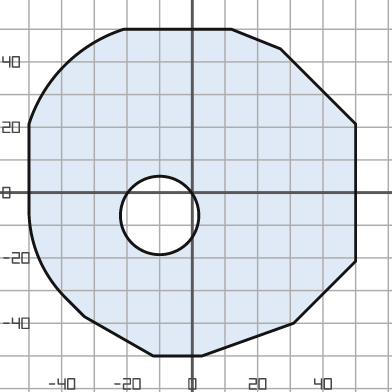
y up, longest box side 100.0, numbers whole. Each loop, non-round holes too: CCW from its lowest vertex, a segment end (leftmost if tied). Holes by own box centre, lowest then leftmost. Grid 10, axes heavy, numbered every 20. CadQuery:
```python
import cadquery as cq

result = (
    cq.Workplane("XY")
    .moveTo(-12.0, -50.0)
    .lineTo(3.0, -50.0)
    .lineTo(31.0, -40.0)
    .lineTo(50.0, -21.0)
    .lineTo(50.0, 21.0)
    .lineTo(27.0, 44.0)
    .lineTo(12.0, 50.0)
    .lineTo(-21.0, 50.0)
    .threePointArc((-39.0, 39.0), (-50.0, 21.0))
    .lineTo(-50.0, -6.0)
    .threePointArc((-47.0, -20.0), (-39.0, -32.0))
    .lineTo(-33.0, -38.0)
    .close()
    .moveTo(-10.0, -7.0)
    .circle(12.0)
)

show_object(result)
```